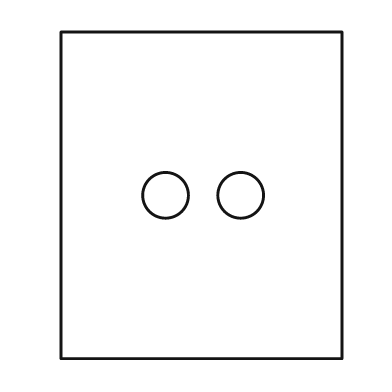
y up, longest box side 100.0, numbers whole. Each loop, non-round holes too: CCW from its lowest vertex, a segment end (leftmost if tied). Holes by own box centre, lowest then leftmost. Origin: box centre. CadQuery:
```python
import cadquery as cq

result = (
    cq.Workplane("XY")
    .moveTo(-43.0, -50.0)
    .lineTo(43.0, -50.0)
    .lineTo(43.0, 50.0)
    .lineTo(-43.0, 50.0)
    .close()
    .moveTo(-11.0, 0.0)
    .circle(7.0)
    .moveTo(12.0, 0.0)
    .circle(7.0)
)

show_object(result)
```